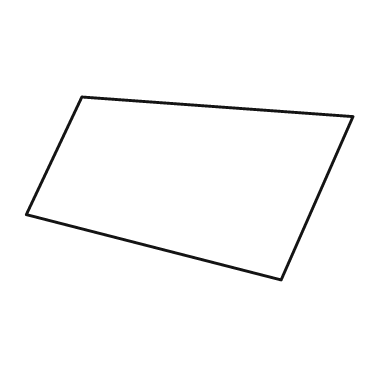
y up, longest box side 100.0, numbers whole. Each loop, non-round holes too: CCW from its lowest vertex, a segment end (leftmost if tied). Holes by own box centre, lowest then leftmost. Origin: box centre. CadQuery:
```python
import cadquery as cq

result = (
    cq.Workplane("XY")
    .moveTo(28.0, -28.0)
    .lineTo(50.0, 22.0)
    .lineTo(-33.0, 28.0)
    .lineTo(-50.0, -8.0)
    .close()
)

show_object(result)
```